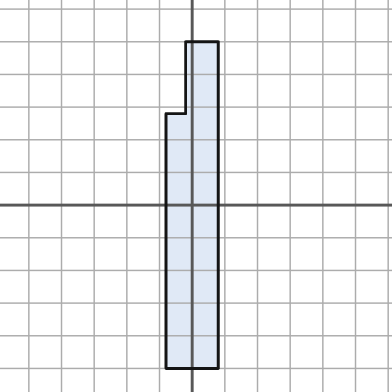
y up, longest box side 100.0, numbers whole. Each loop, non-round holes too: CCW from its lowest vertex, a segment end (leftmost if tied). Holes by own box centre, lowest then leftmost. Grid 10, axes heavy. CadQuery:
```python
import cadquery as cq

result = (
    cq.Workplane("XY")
    .moveTo(-8.0, -50.0)
    .lineTo(8.0, -50.0)
    .lineTo(8.0, 50.0)
    .lineTo(-2.0, 50.0)
    .lineTo(-2.0, 28.0)
    .lineTo(-8.0, 28.0)
    .close()
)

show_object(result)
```